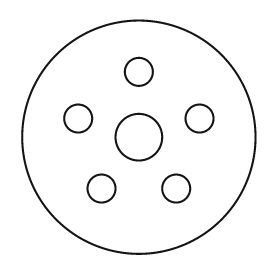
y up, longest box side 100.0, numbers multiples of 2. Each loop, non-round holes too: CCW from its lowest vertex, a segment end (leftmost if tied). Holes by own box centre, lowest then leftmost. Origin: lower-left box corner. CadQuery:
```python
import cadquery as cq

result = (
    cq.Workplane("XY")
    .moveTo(50.0, 50.0)
    .circle(50.0)
    .moveTo(34.0, 28.0)
    .circle(6.0)
    .moveTo(66.0, 28.0)
    .circle(6.0)
    .moveTo(50.0, 50.0)
    .circle(10.0)
    .moveTo(24.0, 58.0)
    .circle(6.0)
    .moveTo(76.0, 58.0)
    .circle(6.0)
    .moveTo(50.0, 78.0)
    .circle(6.0)
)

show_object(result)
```